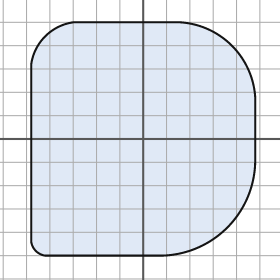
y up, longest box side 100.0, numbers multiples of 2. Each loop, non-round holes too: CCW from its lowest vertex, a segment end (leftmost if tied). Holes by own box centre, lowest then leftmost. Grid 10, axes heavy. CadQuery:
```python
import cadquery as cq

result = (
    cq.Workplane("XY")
    .moveTo(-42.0, -50.0)
    .lineTo(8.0, -50.0)
    .threePointArc((36.0, -38.0), (48.0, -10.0))
    .lineTo(48.0, 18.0)
    .threePointArc((38.0, 40.0), (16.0, 50.0))
    .lineTo(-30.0, 50.0)
    .threePointArc((-42.0, 44.0), (-48.0, 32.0))
    .lineTo(-48.0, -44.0)
    .threePointArc((-46.0, -48.0), (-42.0, -50.0))
    .close()
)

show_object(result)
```